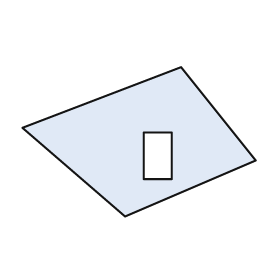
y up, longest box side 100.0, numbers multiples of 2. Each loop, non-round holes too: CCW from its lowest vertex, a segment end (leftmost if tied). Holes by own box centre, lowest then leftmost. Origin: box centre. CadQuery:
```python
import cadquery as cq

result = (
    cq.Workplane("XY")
    .moveTo(-6.0, -32.0)
    .lineTo(50.0, -8.0)
    .lineTo(18.0, 32.0)
    .lineTo(-50.0, 6.0)
    .close()
    .moveTo(2.0, -16.0)
    .lineTo(14.0, -16.0)
    .lineTo(14.0, 4.0)
    .lineTo(2.0, 4.0)
    .close()
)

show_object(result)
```